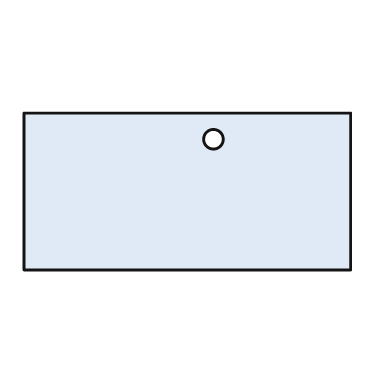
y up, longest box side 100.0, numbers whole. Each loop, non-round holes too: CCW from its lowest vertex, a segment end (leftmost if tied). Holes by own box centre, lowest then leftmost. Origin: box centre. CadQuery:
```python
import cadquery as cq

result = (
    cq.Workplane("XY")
    .moveTo(-50.0, -24.0)
    .lineTo(50.0, -24.0)
    .lineTo(50.0, 24.0)
    .lineTo(-50.0, 24.0)
    .close()
    .moveTo(8.0, 16.0)
    .circle(3.0)
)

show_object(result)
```